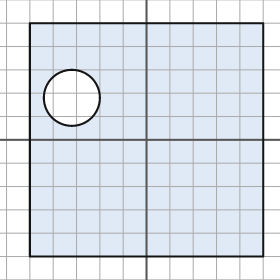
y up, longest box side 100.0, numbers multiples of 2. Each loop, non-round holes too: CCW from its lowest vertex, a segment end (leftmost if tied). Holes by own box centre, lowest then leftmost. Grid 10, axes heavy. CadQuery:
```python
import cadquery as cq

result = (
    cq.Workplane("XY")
    .moveTo(-50.0, -50.0)
    .lineTo(50.0, -50.0)
    .lineTo(50.0, 50.0)
    .lineTo(-50.0, 50.0)
    .close()
    .moveTo(-32.0, 18.0)
    .circle(12.0)
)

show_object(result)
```